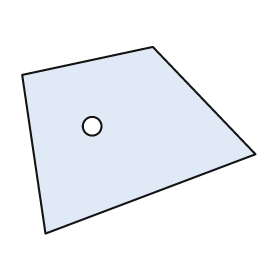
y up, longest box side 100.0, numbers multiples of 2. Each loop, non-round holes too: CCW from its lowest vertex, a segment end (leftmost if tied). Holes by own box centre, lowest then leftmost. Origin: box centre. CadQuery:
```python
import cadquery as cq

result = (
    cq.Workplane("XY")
    .moveTo(-40.0, -40.0)
    .lineTo(50.0, -6.0)
    .lineTo(6.0, 40.0)
    .lineTo(-50.0, 28.0)
    .close()
    .moveTo(-20.0, 6.0)
    .circle(4.0)
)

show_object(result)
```